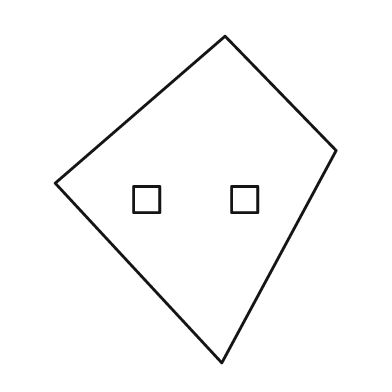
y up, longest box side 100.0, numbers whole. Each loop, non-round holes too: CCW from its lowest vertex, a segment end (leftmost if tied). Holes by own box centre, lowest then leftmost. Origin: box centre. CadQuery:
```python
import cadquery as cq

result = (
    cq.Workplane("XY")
    .moveTo(8.0, -50.0)
    .lineTo(43.0, 15.0)
    .lineTo(9.0, 50.0)
    .lineTo(-43.0, 5.0)
    .close()
    .moveTo(-19.0, -4.0)
    .lineTo(-11.0, -4.0)
    .lineTo(-11.0, 4.0)
    .lineTo(-19.0, 4.0)
    .close()
    .moveTo(11.0, -4.0)
    .lineTo(19.0, -4.0)
    .lineTo(19.0, 4.0)
    .lineTo(11.0, 4.0)
    .close()
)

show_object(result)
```